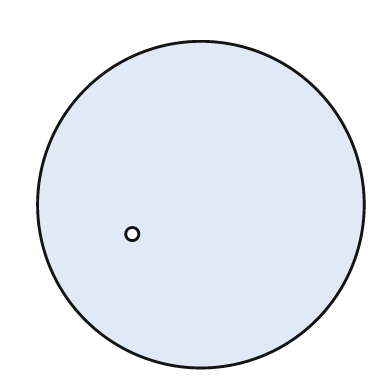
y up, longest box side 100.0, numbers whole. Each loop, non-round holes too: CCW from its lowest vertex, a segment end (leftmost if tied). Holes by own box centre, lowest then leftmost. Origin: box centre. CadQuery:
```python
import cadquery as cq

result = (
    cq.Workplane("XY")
    .moveTo(0.0, 0.0)
    .circle(50.0)
    .moveTo(-21.0, -9.0)
    .circle(2.0)
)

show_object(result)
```